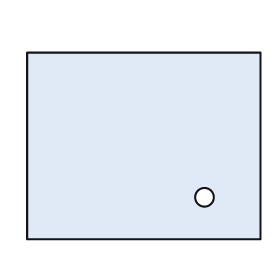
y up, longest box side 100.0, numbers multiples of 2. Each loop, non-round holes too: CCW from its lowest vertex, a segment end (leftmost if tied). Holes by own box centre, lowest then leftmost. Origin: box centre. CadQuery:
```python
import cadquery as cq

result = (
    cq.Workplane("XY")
    .moveTo(-50.0, -40.0)
    .lineTo(50.0, -40.0)
    .lineTo(50.0, 40.0)
    .lineTo(-50.0, 40.0)
    .close()
    .moveTo(26.0, -22.0)
    .circle(4.0)
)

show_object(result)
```